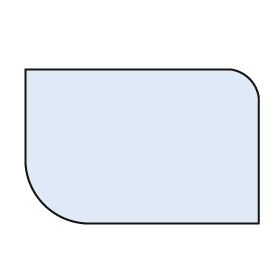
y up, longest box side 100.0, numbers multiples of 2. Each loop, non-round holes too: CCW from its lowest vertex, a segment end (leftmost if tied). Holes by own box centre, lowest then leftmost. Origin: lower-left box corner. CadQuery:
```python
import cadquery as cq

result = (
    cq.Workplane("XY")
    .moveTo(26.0, 0.0)
    .lineTo(100.0, 0.0)
    .lineTo(100.0, 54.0)
    .threePointArc((96.0, 62.0), (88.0, 66.0))
    .lineTo(0.0, 66.0)
    .lineTo(0.0, 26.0)
    .threePointArc((8.0, 8.0), (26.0, 0.0))
    .close()
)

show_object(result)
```